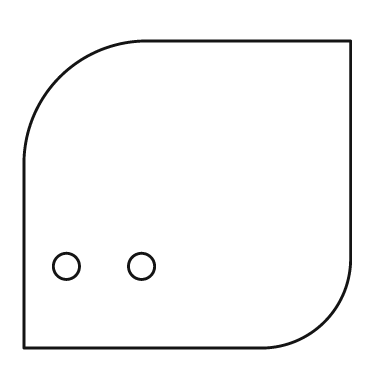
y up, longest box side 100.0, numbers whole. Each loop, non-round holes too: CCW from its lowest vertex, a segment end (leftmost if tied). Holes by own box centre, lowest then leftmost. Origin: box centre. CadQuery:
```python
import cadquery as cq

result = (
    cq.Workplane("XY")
    .moveTo(-50.0, -47.0)
    .lineTo(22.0, -47.0)
    .threePointArc((42.0, -39.0), (50.0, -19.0))
    .lineTo(50.0, 47.0)
    .lineTo(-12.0, 47.0)
    .threePointArc((-39.0, 36.0), (-50.0, 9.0))
    .close()
    .moveTo(-37.0, -22.0)
    .circle(4.0)
    .moveTo(-14.0, -22.0)
    .circle(4.0)
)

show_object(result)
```